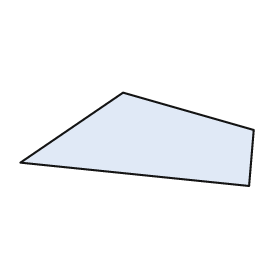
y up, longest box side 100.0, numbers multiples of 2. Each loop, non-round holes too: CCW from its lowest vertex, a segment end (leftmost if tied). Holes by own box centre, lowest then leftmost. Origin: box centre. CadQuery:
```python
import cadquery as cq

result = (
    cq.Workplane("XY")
    .moveTo(48.0, -20.0)
    .lineTo(50.0, 4.0)
    .lineTo(-6.0, 20.0)
    .lineTo(-50.0, -10.0)
    .close()
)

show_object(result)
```